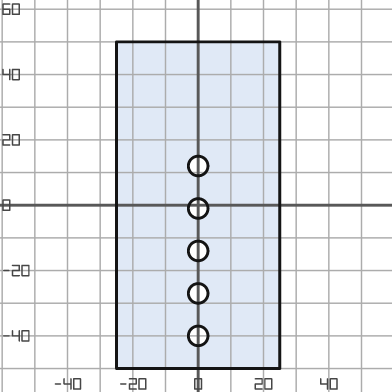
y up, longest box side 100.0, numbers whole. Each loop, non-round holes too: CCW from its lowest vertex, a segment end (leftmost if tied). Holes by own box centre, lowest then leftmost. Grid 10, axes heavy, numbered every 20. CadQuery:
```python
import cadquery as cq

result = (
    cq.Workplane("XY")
    .moveTo(-25.0, -50.0)
    .lineTo(25.0, -50.0)
    .lineTo(25.0, 50.0)
    .lineTo(-25.0, 50.0)
    .close()
    .moveTo(0.0, -40.0)
    .circle(3.0)
    .moveTo(0.0, -27.0)
    .circle(3.0)
    .moveTo(0.0, -14.0)
    .circle(3.0)
    .moveTo(0.0, -1.0)
    .circle(3.0)
    .moveTo(0.0, 12.0)
    .circle(3.0)
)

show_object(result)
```